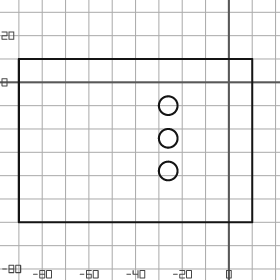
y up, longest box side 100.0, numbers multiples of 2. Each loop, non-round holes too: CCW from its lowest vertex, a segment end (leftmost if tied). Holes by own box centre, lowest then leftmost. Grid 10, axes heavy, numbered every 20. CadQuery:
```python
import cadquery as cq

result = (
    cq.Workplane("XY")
    .moveTo(-90.0, -60.0)
    .lineTo(10.0, -60.0)
    .lineTo(10.0, 10.0)
    .lineTo(-90.0, 10.0)
    .close()
    .moveTo(-26.0, -38.0)
    .circle(4.0)
    .moveTo(-26.0, -24.0)
    .circle(4.0)
    .moveTo(-26.0, -10.0)
    .circle(4.0)
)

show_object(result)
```